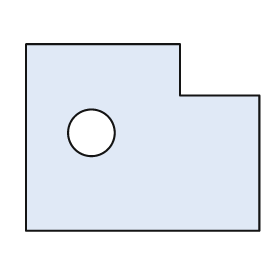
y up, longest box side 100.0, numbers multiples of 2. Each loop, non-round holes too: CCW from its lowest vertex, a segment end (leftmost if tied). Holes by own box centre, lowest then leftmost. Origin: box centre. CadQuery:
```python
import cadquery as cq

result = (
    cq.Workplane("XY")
    .moveTo(-50.0, -40.0)
    .lineTo(50.0, -40.0)
    .lineTo(50.0, 18.0)
    .lineTo(16.0, 18.0)
    .lineTo(16.0, 40.0)
    .lineTo(-50.0, 40.0)
    .close()
    .moveTo(-22.0, 2.0)
    .circle(10.0)
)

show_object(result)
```